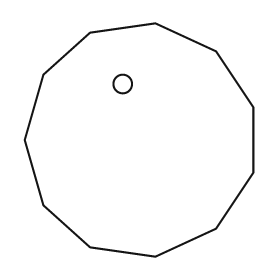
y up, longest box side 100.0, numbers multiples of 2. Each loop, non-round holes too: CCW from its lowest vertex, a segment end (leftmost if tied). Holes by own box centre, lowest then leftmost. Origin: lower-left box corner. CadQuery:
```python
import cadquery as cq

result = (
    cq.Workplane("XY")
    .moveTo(56.0, 0.0)
    .lineTo(82.0, 12.0)
    .lineTo(98.0, 36.0)
    .lineTo(98.0, 64.0)
    .lineTo(82.0, 88.0)
    .lineTo(56.0, 100.0)
    .lineTo(28.0, 96.0)
    .lineTo(8.0, 78.0)
    .lineTo(0.0, 50.0)
    .lineTo(8.0, 22.0)
    .lineTo(28.0, 4.0)
    .close()
    .moveTo(42.0, 74.0)
    .circle(4.0)
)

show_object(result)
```